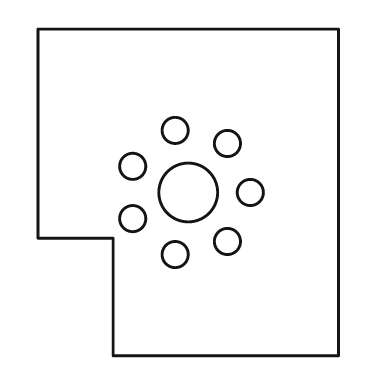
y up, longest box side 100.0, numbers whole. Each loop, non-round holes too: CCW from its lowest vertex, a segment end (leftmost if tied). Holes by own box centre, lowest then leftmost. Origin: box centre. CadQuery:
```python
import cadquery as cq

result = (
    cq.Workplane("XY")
    .moveTo(-23.0, -50.0)
    .lineTo(46.0, -50.0)
    .lineTo(46.0, 50.0)
    .lineTo(-46.0, 50.0)
    .lineTo(-46.0, -14.0)
    .lineTo(-23.0, -14.0)
    .close()
    .moveTo(-4.0, -19.0)
    .circle(4.0)
    .moveTo(12.0, -15.0)
    .circle(4.0)
    .moveTo(-17.0, -8.0)
    .circle(4.0)
    .moveTo(0.0, 0.0)
    .circle(9.0)
    .moveTo(19.0, 0.0)
    .circle(4.0)
    .moveTo(-17.0, 8.0)
    .circle(4.0)
    .moveTo(12.0, 15.0)
    .circle(4.0)
    .moveTo(-4.0, 19.0)
    .circle(4.0)
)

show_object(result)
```